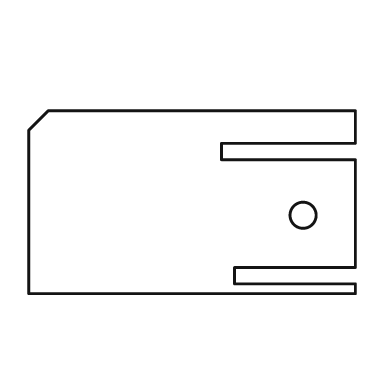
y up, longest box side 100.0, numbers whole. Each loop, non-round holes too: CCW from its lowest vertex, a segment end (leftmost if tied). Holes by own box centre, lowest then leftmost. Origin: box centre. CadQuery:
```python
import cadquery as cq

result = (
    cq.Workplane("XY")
    .moveTo(-50.0, -28.0)
    .lineTo(50.0, -28.0)
    .lineTo(50.0, -25.0)
    .lineTo(13.0, -25.0)
    .lineTo(13.0, -20.0)
    .lineTo(50.0, -20.0)
    .lineTo(50.0, 13.0)
    .lineTo(9.0, 13.0)
    .lineTo(9.0, 18.0)
    .lineTo(50.0, 18.0)
    .lineTo(50.0, 28.0)
    .lineTo(-44.0, 28.0)
    .lineTo(-50.0, 22.0)
    .close()
    .moveTo(34.0, -4.0)
    .circle(4.0)
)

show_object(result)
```